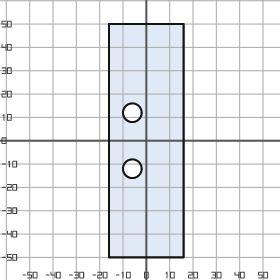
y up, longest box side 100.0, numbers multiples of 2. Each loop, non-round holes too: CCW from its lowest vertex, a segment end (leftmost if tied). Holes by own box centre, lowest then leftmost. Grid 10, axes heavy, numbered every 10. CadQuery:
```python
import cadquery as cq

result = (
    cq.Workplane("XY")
    .moveTo(-16.0, -50.0)
    .lineTo(16.0, -50.0)
    .lineTo(16.0, 50.0)
    .lineTo(-16.0, 50.0)
    .close()
    .moveTo(-6.0, -12.0)
    .circle(4.0)
    .moveTo(-6.0, 12.0)
    .circle(4.0)
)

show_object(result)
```